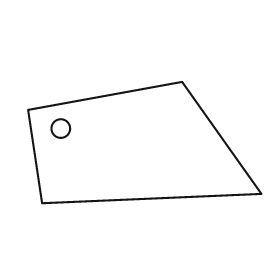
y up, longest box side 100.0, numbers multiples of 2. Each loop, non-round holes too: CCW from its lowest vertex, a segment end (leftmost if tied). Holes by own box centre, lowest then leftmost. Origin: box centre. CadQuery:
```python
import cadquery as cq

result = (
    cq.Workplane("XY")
    .moveTo(-44.0, -26.0)
    .lineTo(50.0, -22.0)
    .lineTo(16.0, 26.0)
    .lineTo(-50.0, 14.0)
    .close()
    .moveTo(-36.0, 6.0)
    .circle(4.0)
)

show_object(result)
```